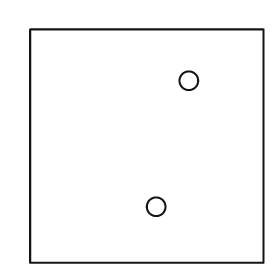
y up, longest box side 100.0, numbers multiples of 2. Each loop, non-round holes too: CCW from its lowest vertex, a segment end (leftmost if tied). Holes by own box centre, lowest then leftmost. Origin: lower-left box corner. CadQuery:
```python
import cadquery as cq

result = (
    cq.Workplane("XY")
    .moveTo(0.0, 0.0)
    .lineTo(100.0, 0.0)
    .lineTo(100.0, 100.0)
    .lineTo(0.0, 100.0)
    .close()
    .moveTo(54.0, 24.0)
    .circle(4.0)
    .moveTo(68.0, 78.0)
    .circle(4.0)
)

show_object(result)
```